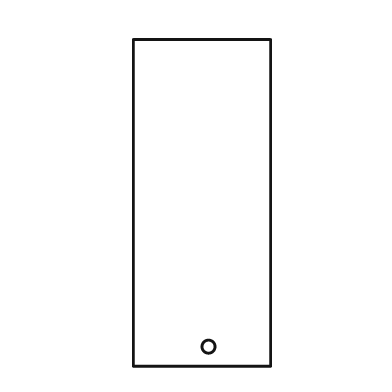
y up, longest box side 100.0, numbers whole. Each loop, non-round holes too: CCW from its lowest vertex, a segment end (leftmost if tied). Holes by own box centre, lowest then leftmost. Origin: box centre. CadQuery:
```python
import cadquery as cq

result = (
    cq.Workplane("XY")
    .moveTo(-21.0, -50.0)
    .lineTo(21.0, -50.0)
    .lineTo(21.0, 50.0)
    .lineTo(-21.0, 50.0)
    .close()
    .moveTo(2.0, -44.0)
    .circle(2.0)
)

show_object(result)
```